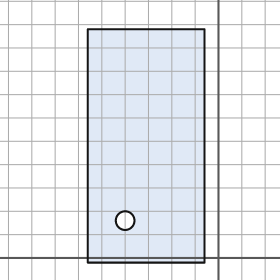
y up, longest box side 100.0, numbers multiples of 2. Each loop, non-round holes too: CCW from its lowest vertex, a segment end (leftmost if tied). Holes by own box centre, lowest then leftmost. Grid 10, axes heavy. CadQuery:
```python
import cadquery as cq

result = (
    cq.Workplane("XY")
    .moveTo(-56.0, -2.0)
    .lineTo(-6.0, -2.0)
    .lineTo(-6.0, 98.0)
    .lineTo(-56.0, 98.0)
    .close()
    .moveTo(-40.0, 16.0)
    .circle(4.0)
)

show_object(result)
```